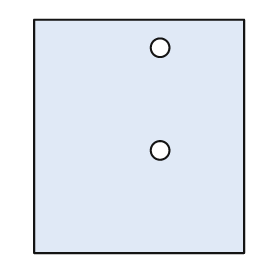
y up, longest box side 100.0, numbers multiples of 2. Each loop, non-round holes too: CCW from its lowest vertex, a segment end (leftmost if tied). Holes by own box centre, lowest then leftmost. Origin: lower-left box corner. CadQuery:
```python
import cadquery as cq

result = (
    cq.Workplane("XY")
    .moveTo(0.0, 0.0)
    .lineTo(90.0, 0.0)
    .lineTo(90.0, 100.0)
    .lineTo(0.0, 100.0)
    .close()
    .moveTo(54.0, 44.0)
    .circle(4.0)
    .moveTo(54.0, 88.0)
    .circle(4.0)
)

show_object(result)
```